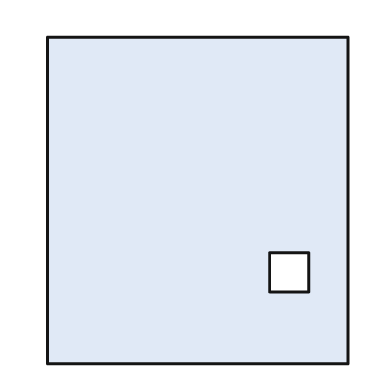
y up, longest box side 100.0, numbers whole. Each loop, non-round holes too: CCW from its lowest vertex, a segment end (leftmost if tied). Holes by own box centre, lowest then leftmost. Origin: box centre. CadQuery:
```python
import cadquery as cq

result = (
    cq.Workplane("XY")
    .moveTo(-46.0, -50.0)
    .lineTo(46.0, -50.0)
    .lineTo(46.0, 50.0)
    .lineTo(-46.0, 50.0)
    .close()
    .moveTo(22.0, -28.0)
    .lineTo(34.0, -28.0)
    .lineTo(34.0, -16.0)
    .lineTo(22.0, -16.0)
    .close()
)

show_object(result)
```